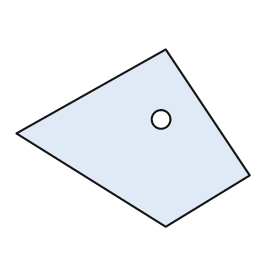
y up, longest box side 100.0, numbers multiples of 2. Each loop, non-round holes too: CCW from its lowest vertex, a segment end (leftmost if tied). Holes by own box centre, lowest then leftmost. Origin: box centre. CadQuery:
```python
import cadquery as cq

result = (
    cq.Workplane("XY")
    .moveTo(14.0, -38.0)
    .lineTo(50.0, -16.0)
    .lineTo(14.0, 38.0)
    .lineTo(-50.0, 2.0)
    .close()
    .moveTo(12.0, 8.0)
    .circle(4.0)
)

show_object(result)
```